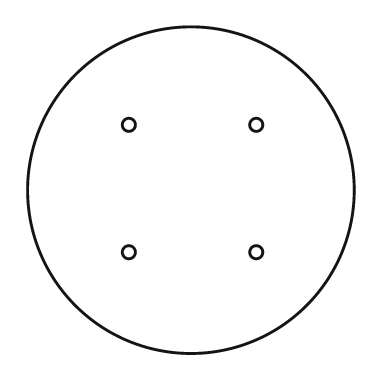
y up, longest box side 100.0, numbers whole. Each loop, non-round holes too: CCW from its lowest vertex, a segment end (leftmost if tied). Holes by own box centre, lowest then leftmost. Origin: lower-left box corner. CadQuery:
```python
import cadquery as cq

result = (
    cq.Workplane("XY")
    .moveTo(50.0, 50.0)
    .circle(50.0)
    .moveTo(31.0, 31.0)
    .circle(2.0)
    .moveTo(70.0, 31.0)
    .circle(2.0)
    .moveTo(31.0, 70.0)
    .circle(2.0)
    .moveTo(70.0, 70.0)
    .circle(2.0)
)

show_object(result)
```